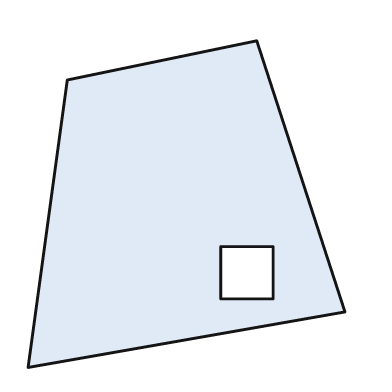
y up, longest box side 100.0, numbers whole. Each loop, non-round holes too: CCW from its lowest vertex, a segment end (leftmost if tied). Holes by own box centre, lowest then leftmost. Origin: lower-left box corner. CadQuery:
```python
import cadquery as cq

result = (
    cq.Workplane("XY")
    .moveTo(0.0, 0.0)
    .lineTo(97.0, 17.0)
    .lineTo(70.0, 100.0)
    .lineTo(12.0, 88.0)
    .close()
    .moveTo(59.0, 21.0)
    .lineTo(75.0, 21.0)
    .lineTo(75.0, 37.0)
    .lineTo(59.0, 37.0)
    .close()
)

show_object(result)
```